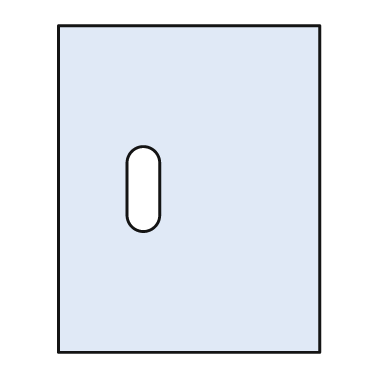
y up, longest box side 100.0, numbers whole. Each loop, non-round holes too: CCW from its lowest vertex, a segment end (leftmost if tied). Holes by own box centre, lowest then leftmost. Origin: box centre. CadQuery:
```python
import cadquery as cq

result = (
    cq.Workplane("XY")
    .moveTo(-40.0, -50.0)
    .lineTo(40.0, -50.0)
    .lineTo(40.0, 50.0)
    .lineTo(-40.0, 50.0)
    .close()
    .moveTo(-19.0, -8.0)
    .threePointArc((-14.0, -13.0), (-9.0, -8.0))
    .lineTo(-9.0, 8.0)
    .threePointArc((-14.0, 13.0), (-19.0, 8.0))
    .close()
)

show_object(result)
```